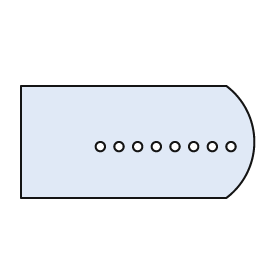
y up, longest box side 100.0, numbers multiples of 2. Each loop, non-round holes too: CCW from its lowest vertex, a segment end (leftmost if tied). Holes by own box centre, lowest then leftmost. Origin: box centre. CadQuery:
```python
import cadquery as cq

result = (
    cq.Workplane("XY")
    .moveTo(-50.0, -24.0)
    .lineTo(38.0, -24.0)
    .threePointArc((50.0, 0.0), (38.0, 24.0))
    .lineTo(-50.0, 24.0)
    .close()
    .moveTo(-16.0, -2.0)
    .circle(2.0)
    .moveTo(-8.0, -2.0)
    .circle(2.0)
    .moveTo(0.0, -2.0)
    .circle(2.0)
    .moveTo(8.0, -2.0)
    .circle(2.0)
    .moveTo(16.0, -2.0)
    .circle(2.0)
    .moveTo(24.0, -2.0)
    .circle(2.0)
    .moveTo(32.0, -2.0)
    .circle(2.0)
    .moveTo(40.0, -2.0)
    .circle(2.0)
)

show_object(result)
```